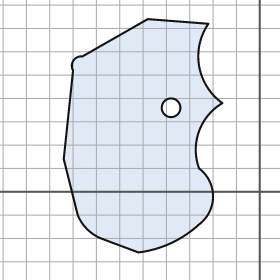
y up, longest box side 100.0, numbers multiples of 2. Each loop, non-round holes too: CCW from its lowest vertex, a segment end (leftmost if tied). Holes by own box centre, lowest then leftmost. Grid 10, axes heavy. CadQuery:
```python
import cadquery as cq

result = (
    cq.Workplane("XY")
    .moveTo(-52.0, -26.0)
    .threePointArc((-38.0, -22.0), (-26.0, -14.0))
    .threePointArc((-20.0, -2.0), (-26.0, 10.0))
    .threePointArc((-26.0, 26.0), (-16.0, 38.0))
    .threePointArc((-26.0, 54.0), (-22.0, 72.0))
    .lineTo(-48.0, 74.0)
    .lineTo(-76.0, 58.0)
    .threePointArc((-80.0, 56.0), (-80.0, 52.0))
    .lineTo(-84.0, 14.0)
    .lineTo(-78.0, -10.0)
    .threePointArc((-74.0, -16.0), (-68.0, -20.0))
    .close()
    .moveTo(-38.0, 36.0)
    .circle(4.0)
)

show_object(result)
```